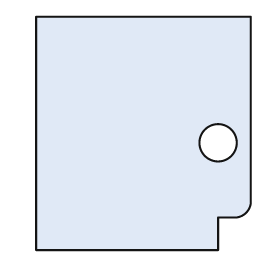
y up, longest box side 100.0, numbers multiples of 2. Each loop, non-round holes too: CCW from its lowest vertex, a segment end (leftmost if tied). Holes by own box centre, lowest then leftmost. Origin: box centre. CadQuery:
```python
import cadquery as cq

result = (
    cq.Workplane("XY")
    .moveTo(-46.0, -50.0)
    .lineTo(32.0, -50.0)
    .lineTo(32.0, -36.0)
    .lineTo(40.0, -36.0)
    .threePointArc((44.0, -34.0), (46.0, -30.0))
    .lineTo(46.0, 50.0)
    .lineTo(-46.0, 50.0)
    .close()
    .moveTo(32.0, -4.0)
    .circle(8.0)
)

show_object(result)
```